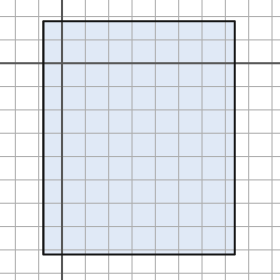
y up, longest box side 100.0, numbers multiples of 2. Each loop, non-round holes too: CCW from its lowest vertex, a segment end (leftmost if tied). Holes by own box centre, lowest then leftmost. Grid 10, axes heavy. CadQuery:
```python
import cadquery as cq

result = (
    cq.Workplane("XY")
    .moveTo(-8.0, -82.0)
    .lineTo(74.0, -82.0)
    .lineTo(74.0, 18.0)
    .lineTo(-8.0, 18.0)
    .close()
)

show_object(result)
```